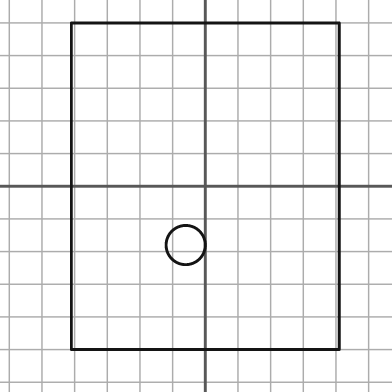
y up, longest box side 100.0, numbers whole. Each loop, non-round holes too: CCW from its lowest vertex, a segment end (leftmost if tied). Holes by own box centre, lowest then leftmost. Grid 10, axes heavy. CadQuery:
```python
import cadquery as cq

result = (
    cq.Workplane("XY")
    .moveTo(-41.0, -50.0)
    .lineTo(41.0, -50.0)
    .lineTo(41.0, 50.0)
    .lineTo(-41.0, 50.0)
    .close()
    .moveTo(-6.0, -18.0)
    .circle(6.0)
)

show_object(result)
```